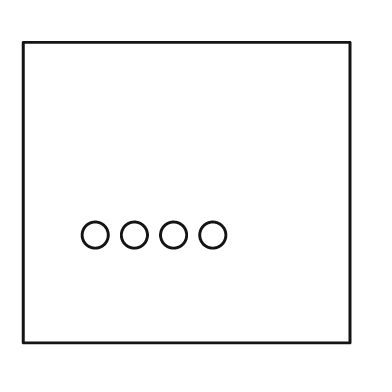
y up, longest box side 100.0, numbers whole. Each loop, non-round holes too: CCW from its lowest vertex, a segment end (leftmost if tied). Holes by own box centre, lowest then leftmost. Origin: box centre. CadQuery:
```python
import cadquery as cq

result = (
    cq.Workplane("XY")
    .moveTo(-50.0, -46.0)
    .lineTo(50.0, -46.0)
    .lineTo(50.0, 46.0)
    .lineTo(-50.0, 46.0)
    .close()
    .moveTo(-28.0, -13.0)
    .circle(4.0)
    .moveTo(-16.0, -13.0)
    .circle(4.0)
    .moveTo(-4.0, -13.0)
    .circle(4.0)
    .moveTo(8.0, -13.0)
    .circle(4.0)
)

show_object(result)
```